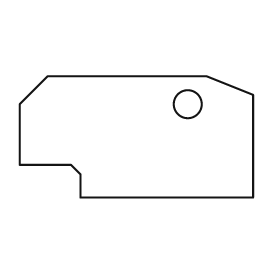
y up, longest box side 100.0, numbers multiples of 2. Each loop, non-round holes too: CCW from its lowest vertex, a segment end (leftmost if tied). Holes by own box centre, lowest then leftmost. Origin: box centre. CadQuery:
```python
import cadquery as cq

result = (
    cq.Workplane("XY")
    .moveTo(-24.0, -26.0)
    .lineTo(50.0, -26.0)
    .lineTo(50.0, 18.0)
    .lineTo(30.0, 26.0)
    .lineTo(-38.0, 26.0)
    .lineTo(-50.0, 14.0)
    .lineTo(-50.0, -12.0)
    .lineTo(-28.0, -12.0)
    .lineTo(-24.0, -16.0)
    .close()
    .moveTo(22.0, 14.0)
    .circle(6.0)
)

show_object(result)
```